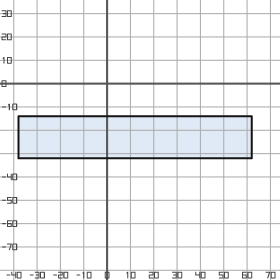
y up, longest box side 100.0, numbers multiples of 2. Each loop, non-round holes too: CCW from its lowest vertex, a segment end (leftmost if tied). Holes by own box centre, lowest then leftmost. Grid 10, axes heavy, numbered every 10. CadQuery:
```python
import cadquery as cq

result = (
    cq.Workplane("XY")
    .moveTo(-38.0, -32.0)
    .lineTo(62.0, -32.0)
    .lineTo(62.0, -14.0)
    .lineTo(-38.0, -14.0)
    .close()
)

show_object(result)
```